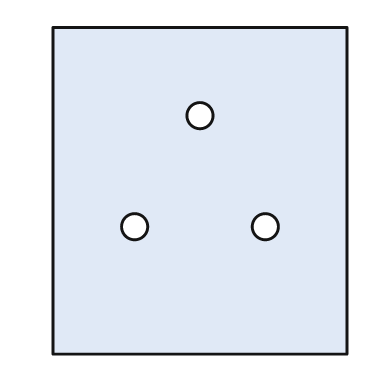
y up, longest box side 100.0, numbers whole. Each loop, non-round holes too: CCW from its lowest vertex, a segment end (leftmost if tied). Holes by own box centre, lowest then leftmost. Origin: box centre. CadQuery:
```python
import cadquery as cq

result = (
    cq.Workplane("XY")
    .moveTo(-45.0, -50.0)
    .lineTo(45.0, -50.0)
    .lineTo(45.0, 50.0)
    .lineTo(-45.0, 50.0)
    .close()
    .moveTo(-20.0, -11.0)
    .circle(4.0)
    .moveTo(20.0, -11.0)
    .circle(4.0)
    .moveTo(0.0, 23.0)
    .circle(4.0)
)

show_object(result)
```